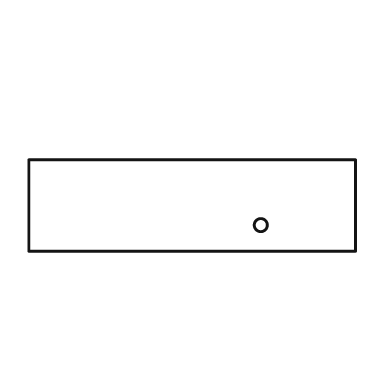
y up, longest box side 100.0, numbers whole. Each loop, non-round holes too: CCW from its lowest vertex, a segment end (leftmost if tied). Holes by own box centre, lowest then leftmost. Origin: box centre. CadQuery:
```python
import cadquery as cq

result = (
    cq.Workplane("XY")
    .moveTo(-50.0, -14.0)
    .lineTo(50.0, -14.0)
    .lineTo(50.0, 14.0)
    .lineTo(-50.0, 14.0)
    .close()
    .moveTo(21.0, -6.0)
    .circle(2.0)
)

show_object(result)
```